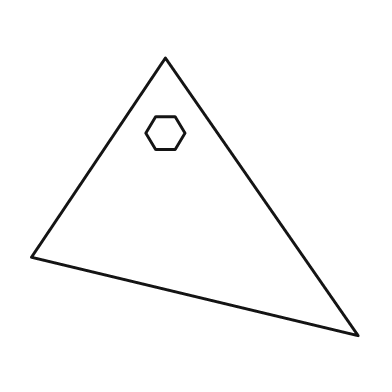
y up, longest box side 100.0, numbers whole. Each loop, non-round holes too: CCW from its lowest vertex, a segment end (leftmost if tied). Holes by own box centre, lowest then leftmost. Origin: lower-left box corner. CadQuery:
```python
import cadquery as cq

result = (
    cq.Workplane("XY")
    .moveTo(100.0, 0.0)
    .lineTo(41.0, 85.0)
    .lineTo(0.0, 24.0)
    .close()
    .moveTo(38.0, 57.0)
    .lineTo(44.0, 57.0)
    .lineTo(47.0, 62.0)
    .lineTo(44.0, 67.0)
    .lineTo(38.0, 67.0)
    .lineTo(35.0, 62.0)
    .close()
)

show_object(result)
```